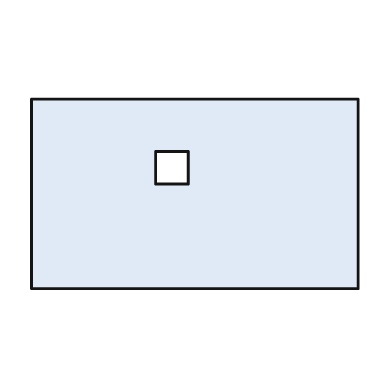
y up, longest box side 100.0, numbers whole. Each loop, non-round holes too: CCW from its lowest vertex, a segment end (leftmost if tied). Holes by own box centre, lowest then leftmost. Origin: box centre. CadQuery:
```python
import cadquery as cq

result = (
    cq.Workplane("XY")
    .moveTo(-50.0, -29.0)
    .lineTo(50.0, -29.0)
    .lineTo(50.0, 29.0)
    .lineTo(-50.0, 29.0)
    .close()
    .moveTo(-12.0, 3.0)
    .lineTo(-2.0, 3.0)
    .lineTo(-2.0, 13.0)
    .lineTo(-12.0, 13.0)
    .close()
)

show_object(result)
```